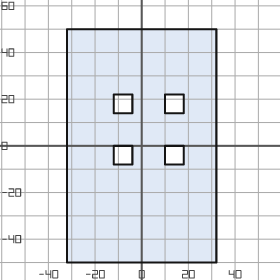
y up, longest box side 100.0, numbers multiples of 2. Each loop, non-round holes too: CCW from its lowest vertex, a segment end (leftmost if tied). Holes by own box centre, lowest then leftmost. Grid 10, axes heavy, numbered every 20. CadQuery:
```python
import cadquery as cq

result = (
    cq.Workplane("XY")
    .moveTo(-32.0, -50.0)
    .lineTo(32.0, -50.0)
    .lineTo(32.0, 50.0)
    .lineTo(-32.0, 50.0)
    .close()
    .moveTo(-12.0, -8.0)
    .lineTo(-4.0, -8.0)
    .lineTo(-4.0, 0.0)
    .lineTo(-12.0, 0.0)
    .close()
    .moveTo(10.0, -8.0)
    .lineTo(18.0, -8.0)
    .lineTo(18.0, 0.0)
    .lineTo(10.0, 0.0)
    .close()
    .moveTo(-12.0, 14.0)
    .lineTo(-4.0, 14.0)
    .lineTo(-4.0, 22.0)
    .lineTo(-12.0, 22.0)
    .close()
    .moveTo(10.0, 14.0)
    .lineTo(18.0, 14.0)
    .lineTo(18.0, 22.0)
    .lineTo(10.0, 22.0)
    .close()
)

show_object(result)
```